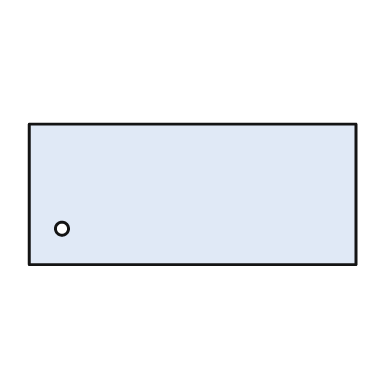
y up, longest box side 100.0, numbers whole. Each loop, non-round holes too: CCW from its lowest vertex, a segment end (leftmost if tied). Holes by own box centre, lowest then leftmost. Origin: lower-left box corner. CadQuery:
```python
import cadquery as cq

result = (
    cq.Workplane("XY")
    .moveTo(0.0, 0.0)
    .lineTo(100.0, 0.0)
    .lineTo(100.0, 43.0)
    .lineTo(0.0, 43.0)
    .close()
    .moveTo(10.0, 11.0)
    .circle(2.0)
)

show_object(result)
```